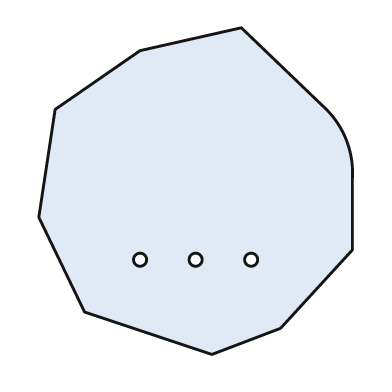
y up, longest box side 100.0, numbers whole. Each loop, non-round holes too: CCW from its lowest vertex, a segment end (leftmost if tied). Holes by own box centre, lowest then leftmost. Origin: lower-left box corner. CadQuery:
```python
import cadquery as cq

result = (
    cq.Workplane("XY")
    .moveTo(53.0, 0.0)
    .lineTo(74.0, 8.0)
    .lineTo(96.0, 32.0)
    .lineTo(96.0, 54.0)
    .threePointArc((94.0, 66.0), (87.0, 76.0))
    .lineTo(62.0, 100.0)
    .lineTo(31.0, 93.0)
    .lineTo(5.0, 75.0)
    .lineTo(0.0, 42.0)
    .lineTo(14.0, 13.0)
    .close()
    .moveTo(31.0, 29.0)
    .circle(2.0)
    .moveTo(48.0, 29.0)
    .circle(2.0)
    .moveTo(65.0, 29.0)
    .circle(2.0)
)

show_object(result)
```